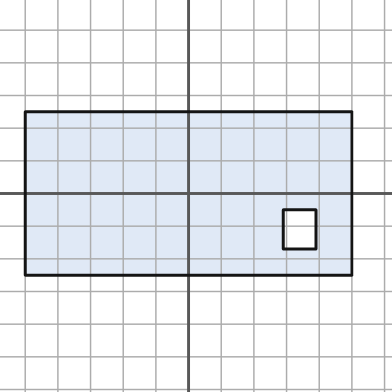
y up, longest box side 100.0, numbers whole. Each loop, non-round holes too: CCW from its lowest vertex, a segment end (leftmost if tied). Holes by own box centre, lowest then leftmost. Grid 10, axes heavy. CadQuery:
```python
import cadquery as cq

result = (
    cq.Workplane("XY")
    .moveTo(-50.0, -25.0)
    .lineTo(50.0, -25.0)
    .lineTo(50.0, 25.0)
    .lineTo(-50.0, 25.0)
    .close()
    .moveTo(29.0, -17.0)
    .lineTo(39.0, -17.0)
    .lineTo(39.0, -5.0)
    .lineTo(29.0, -5.0)
    .close()
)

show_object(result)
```